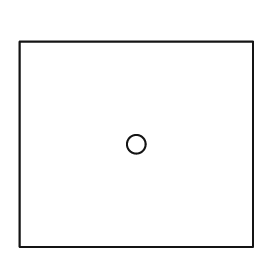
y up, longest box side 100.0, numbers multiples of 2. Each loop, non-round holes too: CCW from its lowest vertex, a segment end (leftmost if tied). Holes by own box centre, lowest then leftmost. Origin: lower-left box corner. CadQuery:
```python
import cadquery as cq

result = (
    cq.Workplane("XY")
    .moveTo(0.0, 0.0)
    .lineTo(100.0, 0.0)
    .lineTo(100.0, 88.0)
    .lineTo(0.0, 88.0)
    .close()
    .moveTo(50.0, 44.0)
    .circle(4.0)
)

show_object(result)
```